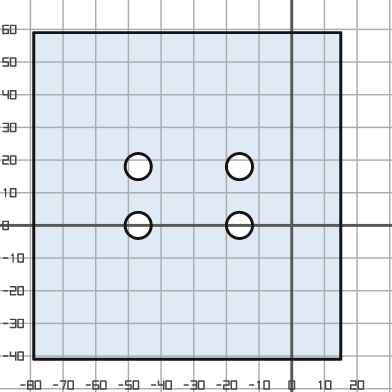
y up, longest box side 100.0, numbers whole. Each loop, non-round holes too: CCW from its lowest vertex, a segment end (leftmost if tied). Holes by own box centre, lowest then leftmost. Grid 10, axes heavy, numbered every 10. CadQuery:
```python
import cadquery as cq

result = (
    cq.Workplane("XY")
    .moveTo(-79.0, -41.0)
    .lineTo(15.0, -41.0)
    .lineTo(15.0, 59.0)
    .lineTo(-79.0, 59.0)
    .close()
    .moveTo(-47.0, 0.0)
    .circle(4.0)
    .moveTo(-16.0, 0.0)
    .circle(4.0)
    .moveTo(-47.0, 18.0)
    .circle(4.0)
    .moveTo(-16.0, 18.0)
    .circle(4.0)
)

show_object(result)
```